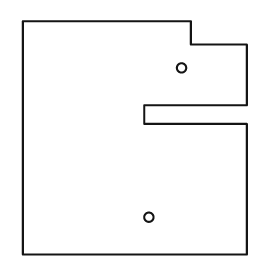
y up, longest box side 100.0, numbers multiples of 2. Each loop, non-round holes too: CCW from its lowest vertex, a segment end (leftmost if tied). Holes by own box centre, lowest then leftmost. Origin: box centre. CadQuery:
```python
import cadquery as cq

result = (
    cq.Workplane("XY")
    .moveTo(-48.0, -50.0)
    .lineTo(48.0, -50.0)
    .lineTo(48.0, 6.0)
    .lineTo(4.0, 6.0)
    .lineTo(4.0, 14.0)
    .lineTo(48.0, 14.0)
    .lineTo(48.0, 40.0)
    .lineTo(24.0, 40.0)
    .lineTo(24.0, 50.0)
    .lineTo(-48.0, 50.0)
    .close()
    .moveTo(6.0, -34.0)
    .circle(2.0)
    .moveTo(20.0, 30.0)
    .circle(2.0)
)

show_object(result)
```